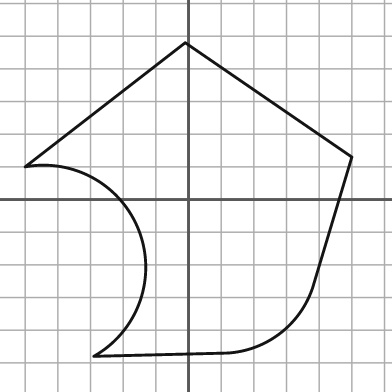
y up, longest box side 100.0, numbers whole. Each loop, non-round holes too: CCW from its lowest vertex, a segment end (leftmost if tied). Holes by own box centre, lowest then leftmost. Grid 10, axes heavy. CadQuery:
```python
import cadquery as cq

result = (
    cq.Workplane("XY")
    .moveTo(-29.0, -48.0)
    .lineTo(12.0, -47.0)
    .threePointArc((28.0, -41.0), (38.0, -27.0))
    .lineTo(50.0, 13.0)
    .lineTo(-1.0, 48.0)
    .lineTo(-50.0, 10.0)
    .threePointArc((-15.0, -10.0), (-29.0, -48.0))
    .close()
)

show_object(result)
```